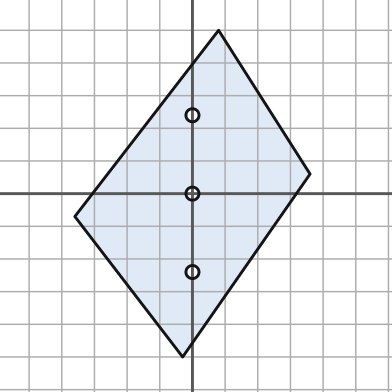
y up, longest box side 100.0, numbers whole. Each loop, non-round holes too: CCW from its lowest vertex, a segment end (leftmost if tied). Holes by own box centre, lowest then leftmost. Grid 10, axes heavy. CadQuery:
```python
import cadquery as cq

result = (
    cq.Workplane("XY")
    .moveTo(-3.0, -50.0)
    .lineTo(36.0, 6.0)
    .lineTo(8.0, 50.0)
    .lineTo(-36.0, -7.0)
    .close()
    .moveTo(0.0, -24.0)
    .circle(2.0)
    .moveTo(0.0, 0.0)
    .circle(2.0)
    .moveTo(0.0, 24.0)
    .circle(2.0)
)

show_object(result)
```